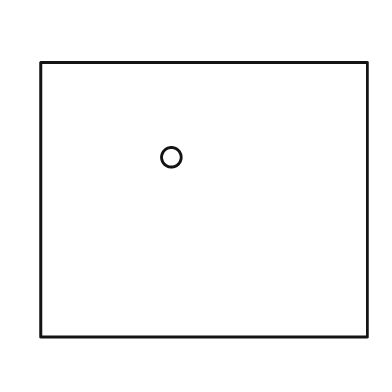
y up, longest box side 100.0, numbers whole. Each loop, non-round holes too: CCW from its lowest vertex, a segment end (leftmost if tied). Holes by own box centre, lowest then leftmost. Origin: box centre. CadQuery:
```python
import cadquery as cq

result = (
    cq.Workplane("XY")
    .moveTo(-50.0, -42.0)
    .lineTo(50.0, -42.0)
    .lineTo(50.0, 42.0)
    .lineTo(-50.0, 42.0)
    .close()
    .moveTo(-10.0, 13.0)
    .circle(3.0)
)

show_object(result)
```